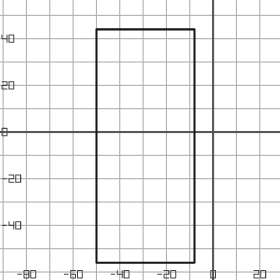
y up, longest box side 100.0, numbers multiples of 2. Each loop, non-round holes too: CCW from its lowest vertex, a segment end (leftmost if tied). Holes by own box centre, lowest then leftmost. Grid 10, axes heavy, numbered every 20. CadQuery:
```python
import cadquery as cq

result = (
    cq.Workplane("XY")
    .moveTo(-50.0, -56.0)
    .lineTo(-8.0, -56.0)
    .lineTo(-8.0, 44.0)
    .lineTo(-50.0, 44.0)
    .close()
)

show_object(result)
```